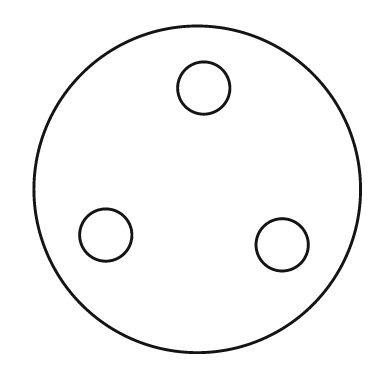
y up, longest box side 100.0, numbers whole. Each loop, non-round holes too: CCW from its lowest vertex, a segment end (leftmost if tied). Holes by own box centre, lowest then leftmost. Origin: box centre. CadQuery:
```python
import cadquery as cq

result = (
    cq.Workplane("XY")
    .moveTo(0.0, 0.0)
    .circle(50.0)
    .moveTo(26.0, -17.0)
    .circle(8.0)
    .moveTo(-28.0, -14.0)
    .circle(8.0)
    .moveTo(2.0, 31.0)
    .circle(8.0)
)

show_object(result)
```